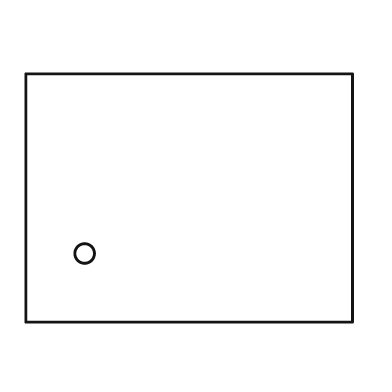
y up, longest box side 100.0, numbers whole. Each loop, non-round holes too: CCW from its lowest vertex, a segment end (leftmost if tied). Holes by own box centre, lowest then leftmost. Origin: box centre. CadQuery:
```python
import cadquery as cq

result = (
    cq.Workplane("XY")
    .moveTo(-50.0, -38.0)
    .lineTo(50.0, -38.0)
    .lineTo(50.0, 38.0)
    .lineTo(-50.0, 38.0)
    .close()
    .moveTo(-32.0, -17.0)
    .circle(3.0)
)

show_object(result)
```